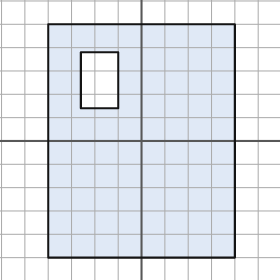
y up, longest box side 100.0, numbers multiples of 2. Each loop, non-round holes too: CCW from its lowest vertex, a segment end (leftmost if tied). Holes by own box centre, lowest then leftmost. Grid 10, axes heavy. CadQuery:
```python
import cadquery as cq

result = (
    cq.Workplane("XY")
    .moveTo(-40.0, -50.0)
    .lineTo(40.0, -50.0)
    .lineTo(40.0, 50.0)
    .lineTo(-40.0, 50.0)
    .close()
    .moveTo(-26.0, 14.0)
    .lineTo(-10.0, 14.0)
    .lineTo(-10.0, 38.0)
    .lineTo(-26.0, 38.0)
    .close()
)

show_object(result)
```